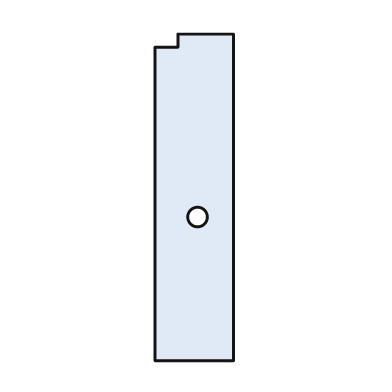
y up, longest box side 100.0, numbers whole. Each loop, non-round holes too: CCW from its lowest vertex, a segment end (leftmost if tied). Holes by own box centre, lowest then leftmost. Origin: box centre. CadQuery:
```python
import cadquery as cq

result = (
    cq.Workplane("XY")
    .moveTo(-12.0, -50.0)
    .lineTo(12.0, -50.0)
    .lineTo(12.0, 50.0)
    .lineTo(-5.0, 50.0)
    .lineTo(-5.0, 46.0)
    .lineTo(-12.0, 46.0)
    .close()
    .moveTo(1.0, -6.0)
    .circle(3.0)
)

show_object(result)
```